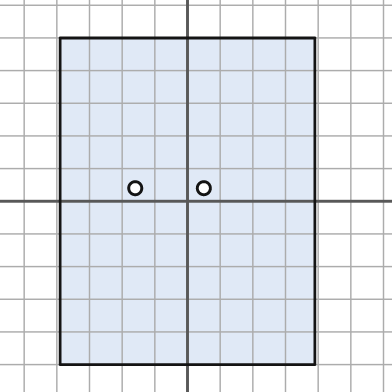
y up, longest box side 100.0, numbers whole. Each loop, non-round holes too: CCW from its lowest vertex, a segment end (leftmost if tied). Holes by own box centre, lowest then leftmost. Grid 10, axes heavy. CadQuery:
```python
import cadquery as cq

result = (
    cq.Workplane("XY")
    .moveTo(-39.0, -50.0)
    .lineTo(39.0, -50.0)
    .lineTo(39.0, 50.0)
    .lineTo(-39.0, 50.0)
    .close()
    .moveTo(-16.0, 4.0)
    .circle(2.0)
    .moveTo(5.0, 4.0)
    .circle(2.0)
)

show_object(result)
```